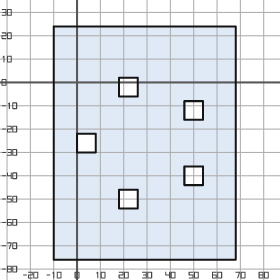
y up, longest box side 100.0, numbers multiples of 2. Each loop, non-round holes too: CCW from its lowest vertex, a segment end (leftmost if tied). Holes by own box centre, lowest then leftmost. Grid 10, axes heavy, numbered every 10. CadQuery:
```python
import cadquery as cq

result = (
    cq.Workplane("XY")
    .moveTo(-10.0, -76.0)
    .lineTo(68.0, -76.0)
    .lineTo(68.0, 24.0)
    .lineTo(-10.0, 24.0)
    .close()
    .moveTo(18.0, -54.0)
    .lineTo(26.0, -54.0)
    .lineTo(26.0, -46.0)
    .lineTo(18.0, -46.0)
    .close()
    .moveTo(46.0, -44.0)
    .lineTo(54.0, -44.0)
    .lineTo(54.0, -36.0)
    .lineTo(46.0, -36.0)
    .close()
    .moveTo(0.0, -30.0)
    .lineTo(8.0, -30.0)
    .lineTo(8.0, -22.0)
    .lineTo(0.0, -22.0)
    .close()
    .moveTo(46.0, -16.0)
    .lineTo(54.0, -16.0)
    .lineTo(54.0, -8.0)
    .lineTo(46.0, -8.0)
    .close()
    .moveTo(18.0, -6.0)
    .lineTo(26.0, -6.0)
    .lineTo(26.0, 2.0)
    .lineTo(18.0, 2.0)
    .close()
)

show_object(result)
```